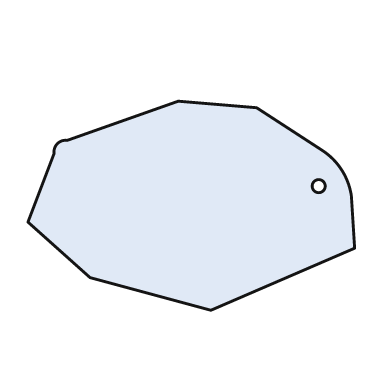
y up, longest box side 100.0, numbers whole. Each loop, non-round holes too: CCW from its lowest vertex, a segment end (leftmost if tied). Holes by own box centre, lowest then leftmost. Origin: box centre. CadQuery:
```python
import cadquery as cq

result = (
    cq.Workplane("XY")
    .moveTo(6.0, -32.0)
    .lineTo(50.0, -13.0)
    .lineTo(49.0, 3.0)
    .threePointArc((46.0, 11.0), (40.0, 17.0))
    .lineTo(20.0, 30.0)
    .lineTo(-4.0, 32.0)
    .lineTo(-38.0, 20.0)
    .threePointArc((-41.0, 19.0), (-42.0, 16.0))
    .lineTo(-50.0, -5.0)
    .lineTo(-31.0, -22.0)
    .close()
    .moveTo(39.0, 6.0)
    .circle(2.0)
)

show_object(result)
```